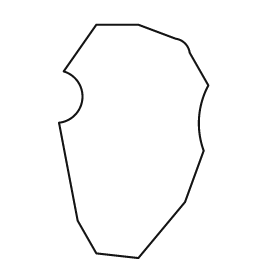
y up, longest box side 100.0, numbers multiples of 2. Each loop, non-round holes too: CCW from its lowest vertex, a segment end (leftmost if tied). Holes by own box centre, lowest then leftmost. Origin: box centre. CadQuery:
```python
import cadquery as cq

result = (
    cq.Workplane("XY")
    .moveTo(2.0, -50.0)
    .lineTo(22.0, -26.0)
    .lineTo(30.0, -4.0)
    .threePointArc((28.0, 10.0), (32.0, 24.0))
    .lineTo(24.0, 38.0)
    .threePointArc((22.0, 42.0), (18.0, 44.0))
    .lineTo(2.0, 50.0)
    .lineTo(-16.0, 50.0)
    .lineTo(-30.0, 30.0)
    .threePointArc((-22.0, 18.0), (-32.0, 8.0))
    .lineTo(-24.0, -34.0)
    .lineTo(-16.0, -48.0)
    .close()
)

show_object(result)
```